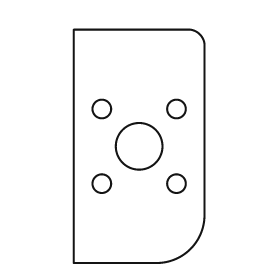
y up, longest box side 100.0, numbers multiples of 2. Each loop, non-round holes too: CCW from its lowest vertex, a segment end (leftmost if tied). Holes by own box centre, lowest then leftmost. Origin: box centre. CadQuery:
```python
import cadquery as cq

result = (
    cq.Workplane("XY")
    .moveTo(-28.0, -50.0)
    .lineTo(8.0, -50.0)
    .threePointArc((22.0, -44.0), (28.0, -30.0))
    .lineTo(28.0, 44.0)
    .threePointArc((26.0, 48.0), (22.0, 50.0))
    .lineTo(-28.0, 50.0)
    .close()
    .moveTo(-16.0, -16.0)
    .circle(4.0)
    .moveTo(16.0, -16.0)
    .circle(4.0)
    .moveTo(0.0, 0.0)
    .circle(10.0)
    .moveTo(-16.0, 16.0)
    .circle(4.0)
    .moveTo(16.0, 16.0)
    .circle(4.0)
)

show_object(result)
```